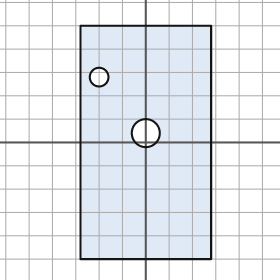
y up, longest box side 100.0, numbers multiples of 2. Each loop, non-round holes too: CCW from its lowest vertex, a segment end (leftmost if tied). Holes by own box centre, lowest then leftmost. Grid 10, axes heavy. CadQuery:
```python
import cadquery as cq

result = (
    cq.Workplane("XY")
    .moveTo(-28.0, -50.0)
    .lineTo(28.0, -50.0)
    .lineTo(28.0, 50.0)
    .lineTo(-28.0, 50.0)
    .close()
    .moveTo(0.0, 4.0)
    .circle(6.0)
    .moveTo(-20.0, 28.0)
    .circle(4.0)
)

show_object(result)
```